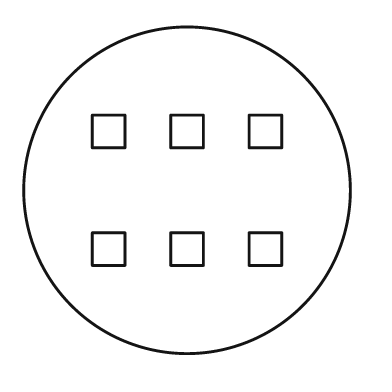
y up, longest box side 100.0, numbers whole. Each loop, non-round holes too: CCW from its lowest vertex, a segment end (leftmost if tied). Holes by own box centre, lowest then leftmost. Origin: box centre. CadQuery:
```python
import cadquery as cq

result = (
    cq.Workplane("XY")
    .moveTo(0.0, 0.0)
    .circle(50.0)
    .moveTo(-29.0, -23.0)
    .lineTo(-19.0, -23.0)
    .lineTo(-19.0, -13.0)
    .lineTo(-29.0, -13.0)
    .close()
    .moveTo(-5.0, -23.0)
    .lineTo(5.0, -23.0)
    .lineTo(5.0, -13.0)
    .lineTo(-5.0, -13.0)
    .close()
    .moveTo(19.0, -23.0)
    .lineTo(29.0, -23.0)
    .lineTo(29.0, -13.0)
    .lineTo(19.0, -13.0)
    .close()
    .moveTo(-29.0, 13.0)
    .lineTo(-19.0, 13.0)
    .lineTo(-19.0, 23.0)
    .lineTo(-29.0, 23.0)
    .close()
    .moveTo(-5.0, 13.0)
    .lineTo(5.0, 13.0)
    .lineTo(5.0, 23.0)
    .lineTo(-5.0, 23.0)
    .close()
    .moveTo(19.0, 13.0)
    .lineTo(29.0, 13.0)
    .lineTo(29.0, 23.0)
    .lineTo(19.0, 23.0)
    .close()
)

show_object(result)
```